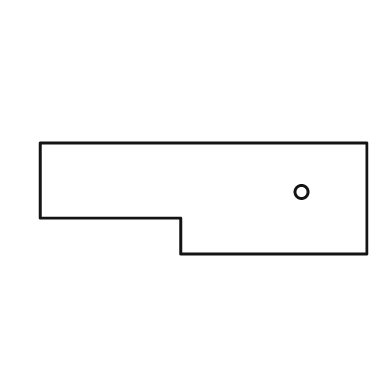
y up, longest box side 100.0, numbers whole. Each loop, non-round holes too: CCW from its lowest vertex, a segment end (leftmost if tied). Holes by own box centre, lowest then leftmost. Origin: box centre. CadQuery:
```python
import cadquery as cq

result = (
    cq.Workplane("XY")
    .moveTo(-7.0, -17.0)
    .lineTo(50.0, -17.0)
    .lineTo(50.0, 17.0)
    .lineTo(-50.0, 17.0)
    .lineTo(-50.0, -6.0)
    .lineTo(-7.0, -6.0)
    .close()
    .moveTo(30.0, 2.0)
    .circle(2.0)
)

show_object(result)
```